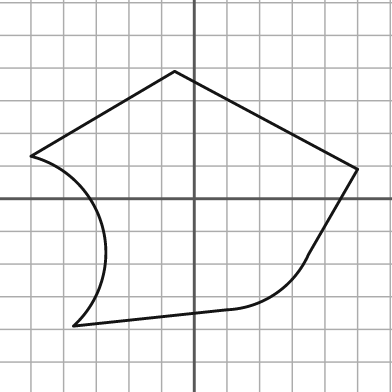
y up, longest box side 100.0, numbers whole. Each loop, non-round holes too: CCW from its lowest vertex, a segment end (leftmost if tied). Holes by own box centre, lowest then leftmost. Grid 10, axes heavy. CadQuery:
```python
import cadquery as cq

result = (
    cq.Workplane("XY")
    .moveTo(-37.0, -39.0)
    .lineTo(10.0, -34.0)
    .threePointArc((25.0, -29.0), (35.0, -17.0))
    .lineTo(50.0, 9.0)
    .lineTo(-6.0, 39.0)
    .lineTo(-50.0, 13.0)
    .threePointArc((-28.0, -9.0), (-37.0, -39.0))
    .close()
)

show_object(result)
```